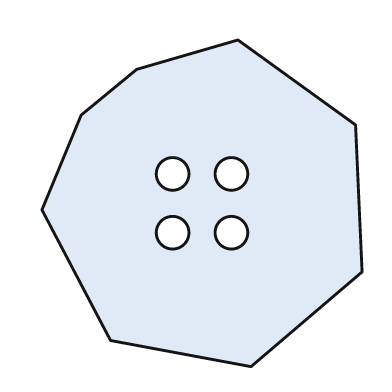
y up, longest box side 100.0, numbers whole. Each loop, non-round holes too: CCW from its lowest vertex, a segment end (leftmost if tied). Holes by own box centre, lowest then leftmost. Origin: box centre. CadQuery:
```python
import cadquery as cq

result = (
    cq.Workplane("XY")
    .moveTo(15.0, -50.0)
    .lineTo(49.0, -21.0)
    .lineTo(47.0, 24.0)
    .lineTo(11.0, 50.0)
    .lineTo(-20.0, 41.0)
    .lineTo(-37.0, 27.0)
    .lineTo(-49.0, -2.0)
    .lineTo(-28.0, -42.0)
    .close()
    .moveTo(-9.0, -9.0)
    .circle(5.0)
    .moveTo(9.0, -9.0)
    .circle(5.0)
    .moveTo(-9.0, 9.0)
    .circle(5.0)
    .moveTo(9.0, 9.0)
    .circle(5.0)
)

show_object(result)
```